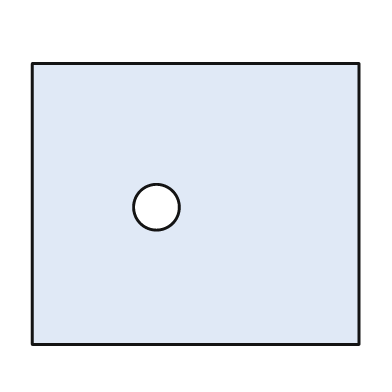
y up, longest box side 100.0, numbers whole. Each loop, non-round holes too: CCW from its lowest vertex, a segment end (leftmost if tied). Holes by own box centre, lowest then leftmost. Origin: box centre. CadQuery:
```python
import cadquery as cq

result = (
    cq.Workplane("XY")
    .moveTo(-50.0, -43.0)
    .lineTo(50.0, -43.0)
    .lineTo(50.0, 43.0)
    .lineTo(-50.0, 43.0)
    .close()
    .moveTo(-12.0, -1.0)
    .circle(7.0)
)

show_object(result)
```